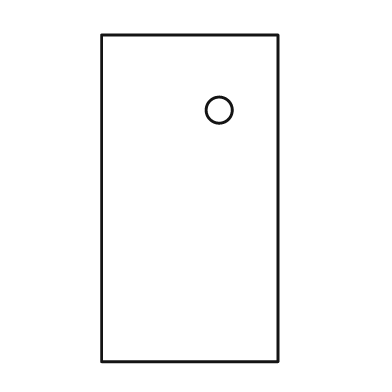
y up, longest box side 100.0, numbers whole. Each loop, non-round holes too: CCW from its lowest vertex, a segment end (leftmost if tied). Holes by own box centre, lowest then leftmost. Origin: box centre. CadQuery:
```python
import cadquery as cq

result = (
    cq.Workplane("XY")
    .moveTo(-27.0, -50.0)
    .lineTo(27.0, -50.0)
    .lineTo(27.0, 50.0)
    .lineTo(-27.0, 50.0)
    .close()
    .moveTo(9.0, 27.0)
    .circle(4.0)
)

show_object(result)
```